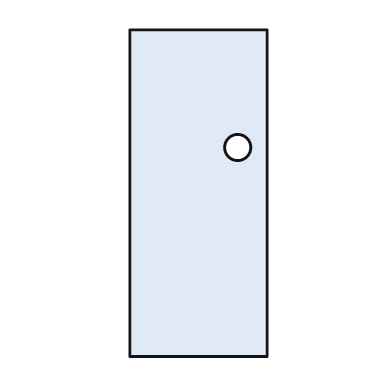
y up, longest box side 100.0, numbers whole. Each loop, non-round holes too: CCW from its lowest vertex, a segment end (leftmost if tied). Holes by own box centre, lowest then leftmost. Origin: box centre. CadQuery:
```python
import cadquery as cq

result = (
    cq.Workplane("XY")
    .moveTo(-21.0, -50.0)
    .lineTo(21.0, -50.0)
    .lineTo(21.0, 50.0)
    .lineTo(-21.0, 50.0)
    .close()
    .moveTo(12.0, 14.0)
    .circle(4.0)
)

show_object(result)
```